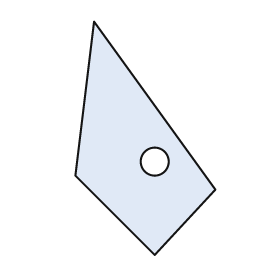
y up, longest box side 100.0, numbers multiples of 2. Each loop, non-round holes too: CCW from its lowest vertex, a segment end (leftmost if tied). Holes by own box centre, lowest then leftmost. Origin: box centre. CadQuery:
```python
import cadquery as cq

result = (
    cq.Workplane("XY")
    .moveTo(4.0, -50.0)
    .lineTo(30.0, -22.0)
    .lineTo(-22.0, 50.0)
    .lineTo(-30.0, -16.0)
    .close()
    .moveTo(4.0, -10.0)
    .circle(6.0)
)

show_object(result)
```